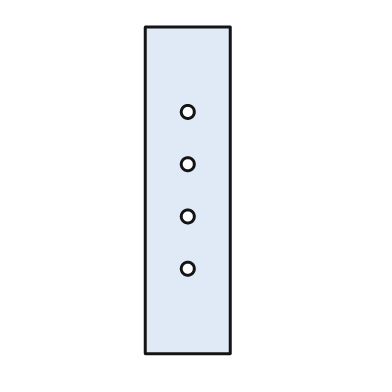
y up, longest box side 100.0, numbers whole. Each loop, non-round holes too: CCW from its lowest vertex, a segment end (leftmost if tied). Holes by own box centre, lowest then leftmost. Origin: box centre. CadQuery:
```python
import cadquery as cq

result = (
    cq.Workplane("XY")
    .moveTo(-13.0, -50.0)
    .lineTo(13.0, -50.0)
    .lineTo(13.0, 50.0)
    .lineTo(-13.0, 50.0)
    .close()
    .moveTo(0.0, -24.0)
    .circle(2.0)
    .moveTo(0.0, -8.0)
    .circle(2.0)
    .moveTo(0.0, 8.0)
    .circle(2.0)
    .moveTo(0.0, 24.0)
    .circle(2.0)
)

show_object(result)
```